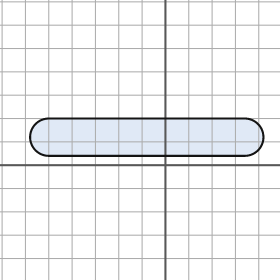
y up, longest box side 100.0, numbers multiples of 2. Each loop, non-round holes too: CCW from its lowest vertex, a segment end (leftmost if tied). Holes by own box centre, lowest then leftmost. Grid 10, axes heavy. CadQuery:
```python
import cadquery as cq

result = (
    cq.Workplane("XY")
    .moveTo(-50.0, 4.0)
    .lineTo(34.0, 4.0)
    .threePointArc((42.0, 12.0), (34.0, 20.0))
    .lineTo(-50.0, 20.0)
    .threePointArc((-58.0, 12.0), (-50.0, 4.0))
    .close()
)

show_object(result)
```